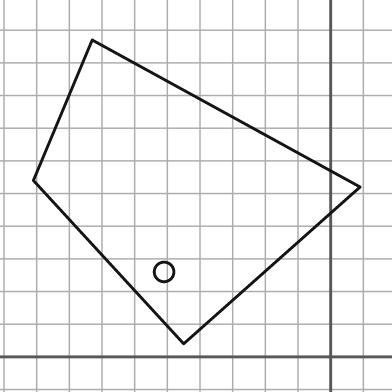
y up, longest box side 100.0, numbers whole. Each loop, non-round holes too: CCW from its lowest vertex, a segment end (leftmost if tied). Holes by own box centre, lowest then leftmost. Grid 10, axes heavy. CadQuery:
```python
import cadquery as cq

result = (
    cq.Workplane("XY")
    .moveTo(-45.0, 4.0)
    .lineTo(9.0, 52.0)
    .lineTo(-73.0, 97.0)
    .lineTo(-91.0, 54.0)
    .close()
    .moveTo(-51.0, 26.0)
    .circle(3.0)
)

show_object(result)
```